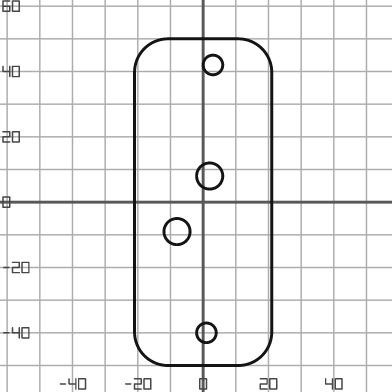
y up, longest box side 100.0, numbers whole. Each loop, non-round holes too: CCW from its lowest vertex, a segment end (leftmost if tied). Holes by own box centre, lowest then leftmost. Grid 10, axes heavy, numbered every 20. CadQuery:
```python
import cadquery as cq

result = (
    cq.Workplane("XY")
    .moveTo(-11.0, -50.0)
    .lineTo(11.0, -50.0)
    .threePointArc((18.0, -47.0), (21.0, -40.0))
    .lineTo(21.0, 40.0)
    .threePointArc((18.0, 47.0), (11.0, 50.0))
    .lineTo(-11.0, 50.0)
    .threePointArc((-18.0, 47.0), (-21.0, 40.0))
    .lineTo(-21.0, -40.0)
    .threePointArc((-18.0, -47.0), (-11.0, -50.0))
    .close()
    .moveTo(1.0, -40.0)
    .circle(3.0)
    .moveTo(-8.0, -9.0)
    .circle(4.0)
    .moveTo(2.0, 8.0)
    .circle(4.0)
    .moveTo(3.0, 42.0)
    .circle(3.0)
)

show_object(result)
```